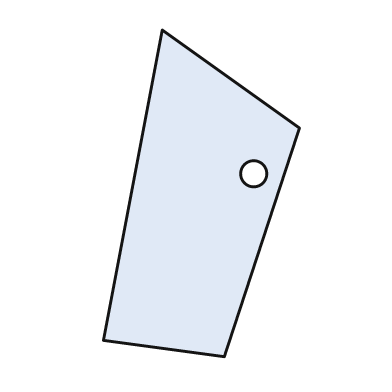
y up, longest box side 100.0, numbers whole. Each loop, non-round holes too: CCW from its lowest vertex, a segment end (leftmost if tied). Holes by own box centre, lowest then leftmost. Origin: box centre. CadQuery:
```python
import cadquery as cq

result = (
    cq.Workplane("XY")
    .moveTo(7.0, -50.0)
    .lineTo(30.0, 20.0)
    .lineTo(-12.0, 50.0)
    .lineTo(-30.0, -45.0)
    .close()
    .moveTo(16.0, 6.0)
    .circle(4.0)
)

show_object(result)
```